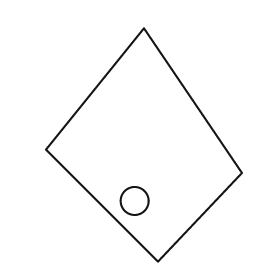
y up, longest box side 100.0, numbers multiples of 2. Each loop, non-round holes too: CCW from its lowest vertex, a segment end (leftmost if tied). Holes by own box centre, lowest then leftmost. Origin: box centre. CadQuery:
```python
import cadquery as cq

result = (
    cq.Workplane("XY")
    .moveTo(6.0, -50.0)
    .lineTo(42.0, -12.0)
    .lineTo(0.0, 50.0)
    .lineTo(-42.0, -2.0)
    .close()
    .moveTo(-4.0, -24.0)
    .circle(6.0)
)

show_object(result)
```